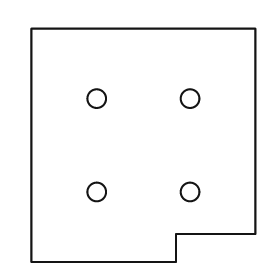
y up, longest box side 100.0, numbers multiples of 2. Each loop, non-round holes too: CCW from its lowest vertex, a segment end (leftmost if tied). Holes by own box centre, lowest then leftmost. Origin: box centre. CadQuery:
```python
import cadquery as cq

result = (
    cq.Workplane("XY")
    .moveTo(-48.0, -50.0)
    .lineTo(14.0, -50.0)
    .lineTo(14.0, -38.0)
    .lineTo(48.0, -38.0)
    .lineTo(48.0, 50.0)
    .lineTo(-48.0, 50.0)
    .close()
    .moveTo(-20.0, -20.0)
    .circle(4.0)
    .moveTo(20.0, -20.0)
    .circle(4.0)
    .moveTo(-20.0, 20.0)
    .circle(4.0)
    .moveTo(20.0, 20.0)
    .circle(4.0)
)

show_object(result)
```